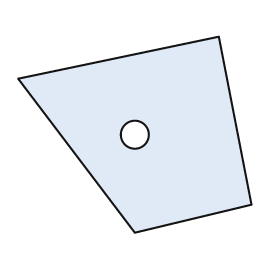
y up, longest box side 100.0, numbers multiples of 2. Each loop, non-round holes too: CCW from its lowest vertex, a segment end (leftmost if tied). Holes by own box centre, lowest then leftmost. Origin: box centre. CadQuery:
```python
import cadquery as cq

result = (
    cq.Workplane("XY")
    .moveTo(0.0, -42.0)
    .lineTo(50.0, -30.0)
    .lineTo(36.0, 42.0)
    .lineTo(-50.0, 24.0)
    .close()
    .moveTo(0.0, 0.0)
    .circle(6.0)
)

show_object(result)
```